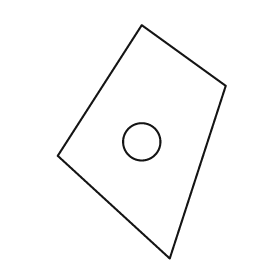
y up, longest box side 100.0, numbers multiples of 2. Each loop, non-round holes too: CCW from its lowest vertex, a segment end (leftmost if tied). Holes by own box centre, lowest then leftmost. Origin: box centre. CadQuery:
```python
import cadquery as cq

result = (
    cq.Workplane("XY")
    .moveTo(12.0, -50.0)
    .lineTo(36.0, 24.0)
    .lineTo(0.0, 50.0)
    .lineTo(-36.0, -6.0)
    .close()
    .moveTo(0.0, 0.0)
    .circle(8.0)
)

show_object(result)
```